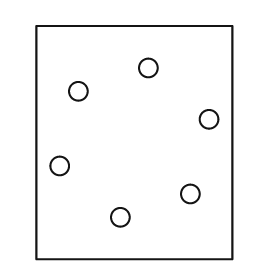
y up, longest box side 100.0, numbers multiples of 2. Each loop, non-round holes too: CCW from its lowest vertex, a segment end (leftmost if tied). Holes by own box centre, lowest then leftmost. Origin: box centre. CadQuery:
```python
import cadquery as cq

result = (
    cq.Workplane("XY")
    .moveTo(-42.0, -50.0)
    .lineTo(42.0, -50.0)
    .lineTo(42.0, 50.0)
    .lineTo(-42.0, 50.0)
    .close()
    .moveTo(-6.0, -32.0)
    .circle(4.0)
    .moveTo(24.0, -22.0)
    .circle(4.0)
    .moveTo(-32.0, -10.0)
    .circle(4.0)
    .moveTo(32.0, 10.0)
    .circle(4.0)
    .moveTo(-24.0, 22.0)
    .circle(4.0)
    .moveTo(6.0, 32.0)
    .circle(4.0)
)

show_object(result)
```